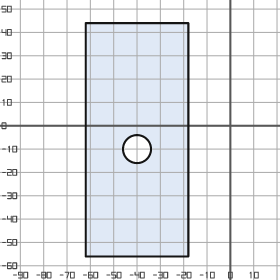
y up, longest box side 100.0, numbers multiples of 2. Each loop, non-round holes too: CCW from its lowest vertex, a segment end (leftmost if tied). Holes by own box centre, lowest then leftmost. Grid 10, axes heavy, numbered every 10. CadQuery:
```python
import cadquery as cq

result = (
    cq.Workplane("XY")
    .moveTo(-62.0, -56.0)
    .lineTo(-18.0, -56.0)
    .lineTo(-18.0, 44.0)
    .lineTo(-62.0, 44.0)
    .close()
    .moveTo(-40.0, -10.0)
    .circle(6.0)
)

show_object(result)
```